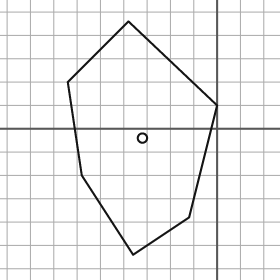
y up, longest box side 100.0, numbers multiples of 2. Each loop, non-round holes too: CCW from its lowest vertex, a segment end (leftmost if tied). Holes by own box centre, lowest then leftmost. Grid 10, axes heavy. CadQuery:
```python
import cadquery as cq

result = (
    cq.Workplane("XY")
    .moveTo(-36.0, -54.0)
    .lineTo(-12.0, -38.0)
    .lineTo(0.0, 10.0)
    .lineTo(-38.0, 46.0)
    .lineTo(-64.0, 20.0)
    .lineTo(-58.0, -20.0)
    .close()
    .moveTo(-32.0, -4.0)
    .circle(2.0)
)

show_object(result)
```